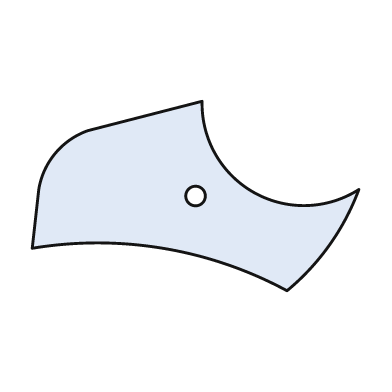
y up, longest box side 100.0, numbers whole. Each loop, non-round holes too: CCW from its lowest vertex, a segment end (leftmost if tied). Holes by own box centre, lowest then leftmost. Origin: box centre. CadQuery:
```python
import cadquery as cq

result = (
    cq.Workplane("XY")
    .moveTo(28.0, -29.0)
    .threePointArc((41.0, -15.0), (50.0, 2.0))
    .threePointArc((18.0, 1.0), (2.0, 29.0))
    .lineTo(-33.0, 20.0)
    .threePointArc((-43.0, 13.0), (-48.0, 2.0))
    .lineTo(-50.0, -16.0)
    .threePointArc((-10.0, -16.0), (28.0, -29.0))
    .close()
    .moveTo(0.0, 0.0)
    .circle(3.0)
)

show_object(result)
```